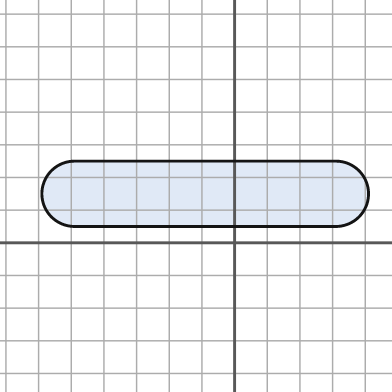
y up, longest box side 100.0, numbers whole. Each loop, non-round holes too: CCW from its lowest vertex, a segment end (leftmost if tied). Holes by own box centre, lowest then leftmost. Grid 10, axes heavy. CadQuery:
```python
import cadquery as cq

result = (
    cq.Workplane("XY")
    .moveTo(-49.0, 5.0)
    .lineTo(31.0, 5.0)
    .threePointArc((41.0, 15.0), (31.0, 25.0))
    .lineTo(-49.0, 25.0)
    .threePointArc((-59.0, 15.0), (-49.0, 5.0))
    .close()
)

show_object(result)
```